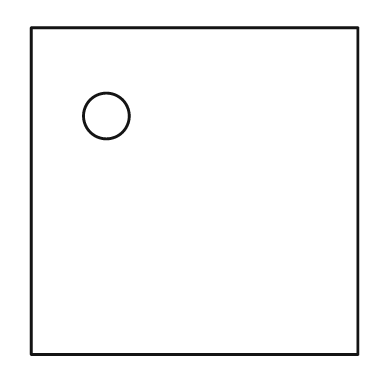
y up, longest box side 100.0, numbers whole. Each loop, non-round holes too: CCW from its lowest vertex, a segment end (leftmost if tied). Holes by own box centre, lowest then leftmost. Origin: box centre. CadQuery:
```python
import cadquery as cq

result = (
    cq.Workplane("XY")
    .moveTo(-50.0, -50.0)
    .lineTo(50.0, -50.0)
    .lineTo(50.0, 50.0)
    .lineTo(-50.0, 50.0)
    .close()
    .moveTo(-27.0, 23.0)
    .circle(7.0)
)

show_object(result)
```